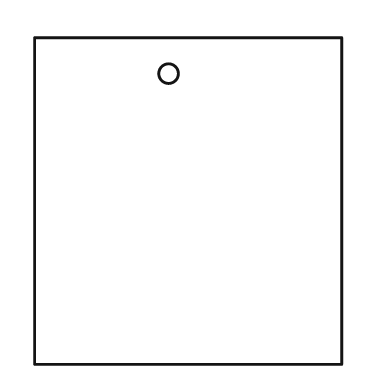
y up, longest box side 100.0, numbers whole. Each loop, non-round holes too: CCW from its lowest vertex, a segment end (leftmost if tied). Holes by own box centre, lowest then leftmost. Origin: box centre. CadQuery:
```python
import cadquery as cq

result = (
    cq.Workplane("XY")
    .moveTo(-47.0, -50.0)
    .lineTo(47.0, -50.0)
    .lineTo(47.0, 50.0)
    .lineTo(-47.0, 50.0)
    .close()
    .moveTo(-6.0, 39.0)
    .circle(3.0)
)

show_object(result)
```